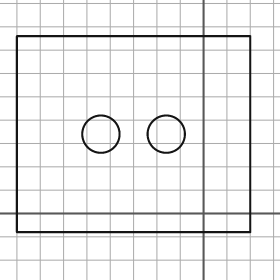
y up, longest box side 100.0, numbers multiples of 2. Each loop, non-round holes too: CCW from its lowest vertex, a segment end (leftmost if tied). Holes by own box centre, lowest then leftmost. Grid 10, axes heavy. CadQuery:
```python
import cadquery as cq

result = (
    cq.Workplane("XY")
    .moveTo(-80.0, -8.0)
    .lineTo(20.0, -8.0)
    .lineTo(20.0, 76.0)
    .lineTo(-80.0, 76.0)
    .close()
    .moveTo(-44.0, 34.0)
    .circle(8.0)
    .moveTo(-16.0, 34.0)
    .circle(8.0)
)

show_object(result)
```